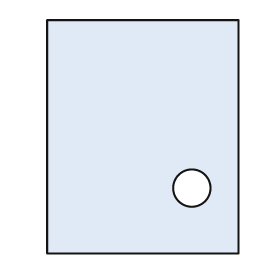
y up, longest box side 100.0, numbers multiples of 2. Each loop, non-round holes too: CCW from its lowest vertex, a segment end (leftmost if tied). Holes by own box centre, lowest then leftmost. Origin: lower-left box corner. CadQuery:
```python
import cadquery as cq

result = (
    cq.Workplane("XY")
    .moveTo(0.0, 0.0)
    .lineTo(82.0, 0.0)
    .lineTo(82.0, 100.0)
    .lineTo(0.0, 100.0)
    .close()
    .moveTo(62.0, 28.0)
    .circle(8.0)
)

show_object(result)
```